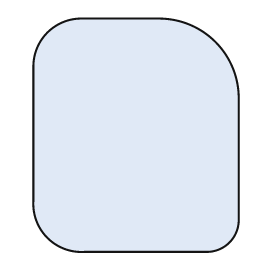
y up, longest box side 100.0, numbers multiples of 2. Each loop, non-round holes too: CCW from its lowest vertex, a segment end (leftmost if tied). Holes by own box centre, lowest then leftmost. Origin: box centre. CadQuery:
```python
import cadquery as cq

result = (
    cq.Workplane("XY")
    .moveTo(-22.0, -50.0)
    .lineTo(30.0, -50.0)
    .threePointArc((40.0, -46.0), (44.0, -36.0))
    .lineTo(44.0, 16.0)
    .threePointArc((34.0, 40.0), (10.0, 50.0))
    .lineTo(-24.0, 50.0)
    .threePointArc((-38.0, 44.0), (-44.0, 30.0))
    .lineTo(-44.0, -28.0)
    .threePointArc((-38.0, -44.0), (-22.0, -50.0))
    .close()
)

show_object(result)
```